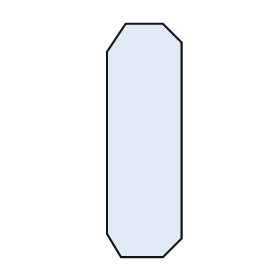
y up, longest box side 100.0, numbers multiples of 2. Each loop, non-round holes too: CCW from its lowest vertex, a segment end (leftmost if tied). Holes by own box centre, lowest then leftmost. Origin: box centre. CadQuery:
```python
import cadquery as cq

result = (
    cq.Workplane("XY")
    .moveTo(-10.0, -50.0)
    .lineTo(8.0, -50.0)
    .lineTo(16.0, -42.0)
    .lineTo(16.0, 42.0)
    .lineTo(8.0, 50.0)
    .lineTo(-8.0, 50.0)
    .lineTo(-16.0, 38.0)
    .lineTo(-16.0, -40.0)
    .close()
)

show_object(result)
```